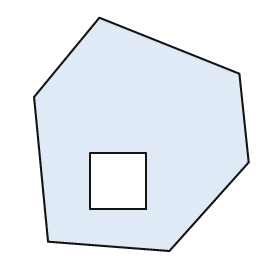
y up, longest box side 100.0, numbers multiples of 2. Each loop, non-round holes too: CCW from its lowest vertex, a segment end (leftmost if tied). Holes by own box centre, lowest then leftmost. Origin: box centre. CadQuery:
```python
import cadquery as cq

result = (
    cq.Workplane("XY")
    .moveTo(12.0, -50.0)
    .lineTo(46.0, -12.0)
    .lineTo(42.0, 26.0)
    .lineTo(-18.0, 50.0)
    .lineTo(-46.0, 16.0)
    .lineTo(-40.0, -46.0)
    .close()
    .moveTo(-22.0, -32.0)
    .lineTo(2.0, -32.0)
    .lineTo(2.0, -8.0)
    .lineTo(-22.0, -8.0)
    .close()
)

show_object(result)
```